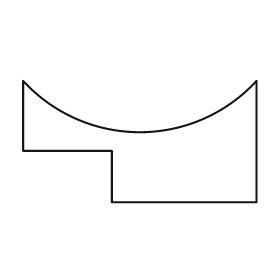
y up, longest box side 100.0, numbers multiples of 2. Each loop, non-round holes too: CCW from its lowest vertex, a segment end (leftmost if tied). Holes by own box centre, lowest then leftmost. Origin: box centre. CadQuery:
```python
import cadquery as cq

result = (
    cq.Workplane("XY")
    .moveTo(-12.0, -26.0)
    .lineTo(50.0, -26.0)
    .lineTo(50.0, 26.0)
    .threePointArc((0.0, 4.0), (-50.0, 26.0))
    .lineTo(-50.0, -4.0)
    .lineTo(-12.0, -4.0)
    .close()
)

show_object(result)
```